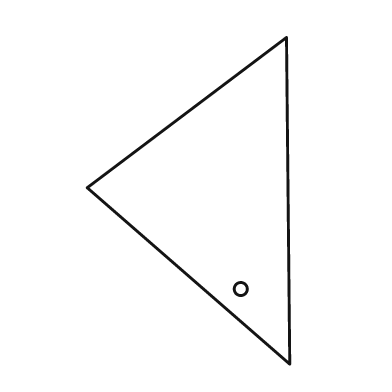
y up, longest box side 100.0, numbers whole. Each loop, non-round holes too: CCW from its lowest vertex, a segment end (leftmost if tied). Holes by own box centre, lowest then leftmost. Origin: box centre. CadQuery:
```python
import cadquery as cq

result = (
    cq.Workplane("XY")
    .moveTo(31.0, -50.0)
    .lineTo(30.0, 50.0)
    .lineTo(-31.0, 4.0)
    .close()
    .moveTo(16.0, -27.0)
    .circle(2.0)
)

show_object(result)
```